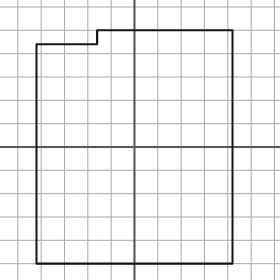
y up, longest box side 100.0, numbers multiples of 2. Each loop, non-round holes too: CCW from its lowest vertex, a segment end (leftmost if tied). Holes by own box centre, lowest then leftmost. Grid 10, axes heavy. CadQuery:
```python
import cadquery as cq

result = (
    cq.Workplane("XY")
    .moveTo(-42.0, -50.0)
    .lineTo(42.0, -50.0)
    .lineTo(42.0, 50.0)
    .lineTo(-16.0, 50.0)
    .lineTo(-16.0, 44.0)
    .lineTo(-42.0, 44.0)
    .close()
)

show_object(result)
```